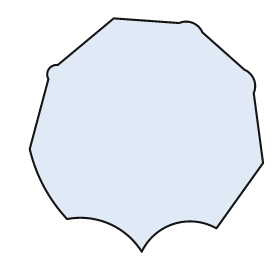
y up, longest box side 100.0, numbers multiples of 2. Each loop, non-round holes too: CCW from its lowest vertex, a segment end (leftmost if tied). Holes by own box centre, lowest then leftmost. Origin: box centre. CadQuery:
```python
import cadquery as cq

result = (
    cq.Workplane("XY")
    .moveTo(-2.0, -50.0)
    .threePointArc((12.0, -38.0), (30.0, -40.0))
    .lineTo(50.0, -12.0)
    .lineTo(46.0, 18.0)
    .threePointArc((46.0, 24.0), (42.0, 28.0))
    .lineTo(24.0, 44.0)
    .threePointArc((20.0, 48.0), (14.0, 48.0))
    .lineTo(-14.0, 50.0)
    .lineTo(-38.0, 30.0)
    .threePointArc((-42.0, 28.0), (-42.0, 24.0))
    .lineTo(-50.0, -6.0)
    .threePointArc((-44.0, -22.0), (-34.0, -36.0))
    .threePointArc((-16.0, -38.0), (-2.0, -50.0))
    .close()
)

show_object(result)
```